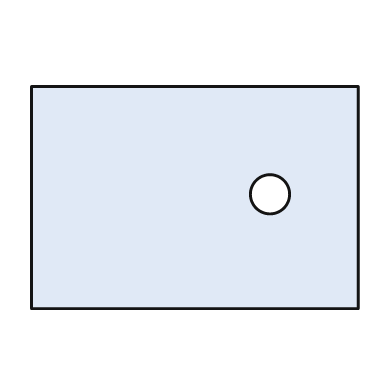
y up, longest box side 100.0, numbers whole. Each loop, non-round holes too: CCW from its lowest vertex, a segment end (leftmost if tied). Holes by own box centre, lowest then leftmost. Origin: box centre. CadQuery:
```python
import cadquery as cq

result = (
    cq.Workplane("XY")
    .moveTo(-50.0, -34.0)
    .lineTo(50.0, -34.0)
    .lineTo(50.0, 34.0)
    .lineTo(-50.0, 34.0)
    .close()
    .moveTo(23.0, 1.0)
    .circle(6.0)
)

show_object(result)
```